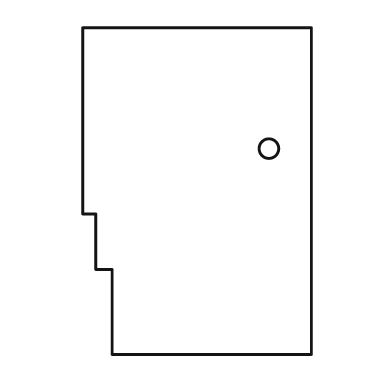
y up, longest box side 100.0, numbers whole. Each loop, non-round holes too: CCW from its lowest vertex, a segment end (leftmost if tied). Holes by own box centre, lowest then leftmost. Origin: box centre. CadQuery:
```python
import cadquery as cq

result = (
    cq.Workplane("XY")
    .moveTo(-26.0, -50.0)
    .lineTo(35.0, -50.0)
    .lineTo(35.0, 50.0)
    .lineTo(-35.0, 50.0)
    .lineTo(-35.0, -7.0)
    .lineTo(-31.0, -7.0)
    .lineTo(-31.0, -24.0)
    .lineTo(-26.0, -24.0)
    .close()
    .moveTo(22.0, 13.0)
    .circle(3.0)
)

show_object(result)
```